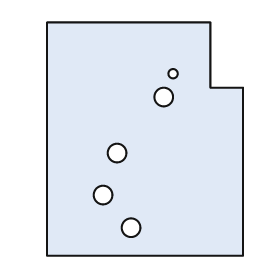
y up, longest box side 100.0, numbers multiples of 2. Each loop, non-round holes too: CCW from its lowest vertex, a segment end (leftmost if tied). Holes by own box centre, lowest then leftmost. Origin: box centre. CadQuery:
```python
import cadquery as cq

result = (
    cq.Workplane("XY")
    .moveTo(-42.0, -50.0)
    .lineTo(42.0, -50.0)
    .lineTo(42.0, 22.0)
    .lineTo(28.0, 22.0)
    .lineTo(28.0, 50.0)
    .lineTo(-42.0, 50.0)
    .close()
    .moveTo(-6.0, -38.0)
    .circle(4.0)
    .moveTo(-18.0, -24.0)
    .circle(4.0)
    .moveTo(-12.0, -6.0)
    .circle(4.0)
    .moveTo(8.0, 18.0)
    .circle(4.0)
    .moveTo(12.0, 28.0)
    .circle(2.0)
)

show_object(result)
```